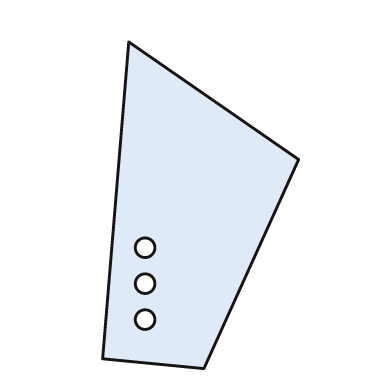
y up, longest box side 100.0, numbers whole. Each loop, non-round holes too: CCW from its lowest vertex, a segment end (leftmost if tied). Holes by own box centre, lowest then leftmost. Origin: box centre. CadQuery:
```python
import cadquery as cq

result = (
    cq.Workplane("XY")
    .moveTo(1.0, -50.0)
    .lineTo(30.0, 14.0)
    .lineTo(-22.0, 50.0)
    .lineTo(-30.0, -47.0)
    .close()
    .moveTo(-17.0, -35.0)
    .circle(3.0)
    .moveTo(-17.0, -24.0)
    .circle(3.0)
    .moveTo(-17.0, -13.0)
    .circle(3.0)
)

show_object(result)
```